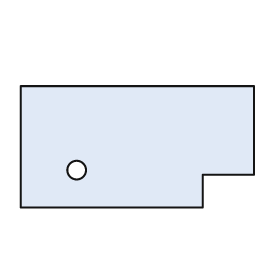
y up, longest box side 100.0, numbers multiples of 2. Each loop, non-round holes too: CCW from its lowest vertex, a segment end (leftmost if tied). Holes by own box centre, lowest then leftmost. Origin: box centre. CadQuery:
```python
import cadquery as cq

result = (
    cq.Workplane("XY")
    .moveTo(-50.0, -26.0)
    .lineTo(28.0, -26.0)
    .lineTo(28.0, -12.0)
    .lineTo(50.0, -12.0)
    .lineTo(50.0, 26.0)
    .lineTo(-50.0, 26.0)
    .close()
    .moveTo(-26.0, -10.0)
    .circle(4.0)
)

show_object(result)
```